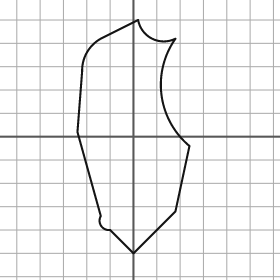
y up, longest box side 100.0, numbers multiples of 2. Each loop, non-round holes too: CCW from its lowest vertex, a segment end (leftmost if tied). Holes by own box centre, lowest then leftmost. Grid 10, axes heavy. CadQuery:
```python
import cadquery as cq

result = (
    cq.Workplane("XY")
    .moveTo(0.0, -50.0)
    .lineTo(18.0, -32.0)
    .lineTo(24.0, -4.0)
    .threePointArc((12.0, 18.0), (18.0, 42.0))
    .threePointArc((8.0, 42.0), (2.0, 50.0))
    .lineTo(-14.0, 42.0)
    .threePointArc((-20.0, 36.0), (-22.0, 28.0))
    .lineTo(-24.0, 2.0)
    .lineTo(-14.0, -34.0)
    .threePointArc((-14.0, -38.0), (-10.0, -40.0))
    .close()
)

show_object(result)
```